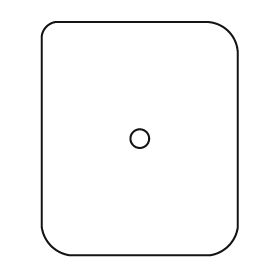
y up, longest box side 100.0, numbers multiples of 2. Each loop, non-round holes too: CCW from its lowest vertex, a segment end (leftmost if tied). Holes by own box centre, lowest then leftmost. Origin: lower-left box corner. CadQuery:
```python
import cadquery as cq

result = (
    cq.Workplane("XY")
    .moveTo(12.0, 0.0)
    .lineTo(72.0, 0.0)
    .threePointArc((80.0, 4.0), (84.0, 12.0))
    .lineTo(84.0, 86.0)
    .threePointArc((80.0, 96.0), (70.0, 100.0))
    .lineTo(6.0, 100.0)
    .threePointArc((2.0, 98.0), (0.0, 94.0))
    .lineTo(0.0, 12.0)
    .threePointArc((4.0, 4.0), (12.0, 0.0))
    .close()
    .moveTo(42.0, 50.0)
    .circle(4.0)
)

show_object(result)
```